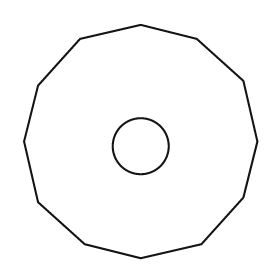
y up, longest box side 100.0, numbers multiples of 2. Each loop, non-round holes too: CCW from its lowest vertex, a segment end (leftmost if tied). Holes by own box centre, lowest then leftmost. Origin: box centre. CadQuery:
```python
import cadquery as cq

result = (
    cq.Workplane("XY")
    .moveTo(0.0, -50.0)
    .lineTo(26.0, -44.0)
    .lineTo(44.0, -24.0)
    .lineTo(50.0, 0.0)
    .lineTo(44.0, 26.0)
    .lineTo(24.0, 44.0)
    .lineTo(0.0, 50.0)
    .lineTo(-26.0, 44.0)
    .lineTo(-44.0, 24.0)
    .lineTo(-50.0, 0.0)
    .lineTo(-44.0, -26.0)
    .lineTo(-24.0, -44.0)
    .close()
    .moveTo(0.0, -2.0)
    .circle(12.0)
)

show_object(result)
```